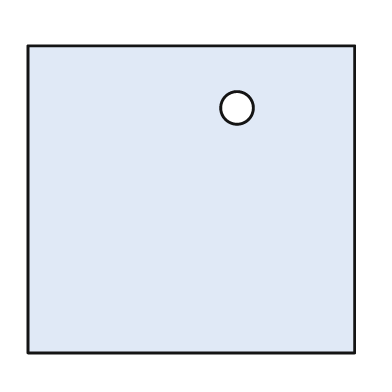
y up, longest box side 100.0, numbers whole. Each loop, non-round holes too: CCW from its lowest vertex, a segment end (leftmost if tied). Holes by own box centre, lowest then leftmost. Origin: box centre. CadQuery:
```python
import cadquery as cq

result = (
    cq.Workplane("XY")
    .moveTo(-50.0, -47.0)
    .lineTo(50.0, -47.0)
    .lineTo(50.0, 47.0)
    .lineTo(-50.0, 47.0)
    .close()
    .moveTo(14.0, 28.0)
    .circle(5.0)
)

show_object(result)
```